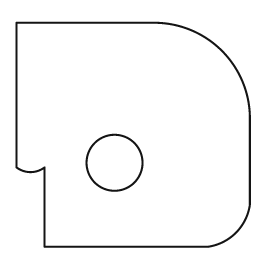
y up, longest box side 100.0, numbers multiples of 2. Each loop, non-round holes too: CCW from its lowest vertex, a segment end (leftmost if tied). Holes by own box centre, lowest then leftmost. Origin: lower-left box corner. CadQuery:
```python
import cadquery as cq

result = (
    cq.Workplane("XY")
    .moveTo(12.0, 0.0)
    .lineTo(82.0, 0.0)
    .threePointArc((94.0, 6.0), (100.0, 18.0))
    .lineTo(100.0, 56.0)
    .threePointArc((88.0, 84.0), (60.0, 96.0))
    .lineTo(0.0, 96.0)
    .lineTo(0.0, 34.0)
    .threePointArc((6.0, 32.0), (12.0, 34.0))
    .close()
    .moveTo(42.0, 36.0)
    .circle(12.0)
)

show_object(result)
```